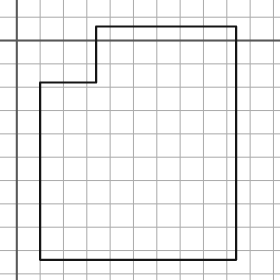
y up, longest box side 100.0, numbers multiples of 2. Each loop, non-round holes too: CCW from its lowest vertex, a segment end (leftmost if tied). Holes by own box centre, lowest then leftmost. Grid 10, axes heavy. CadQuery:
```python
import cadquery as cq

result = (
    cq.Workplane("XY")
    .moveTo(10.0, -94.0)
    .lineTo(94.0, -94.0)
    .lineTo(94.0, 6.0)
    .lineTo(34.0, 6.0)
    .lineTo(34.0, -18.0)
    .lineTo(10.0, -18.0)
    .close()
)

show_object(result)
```